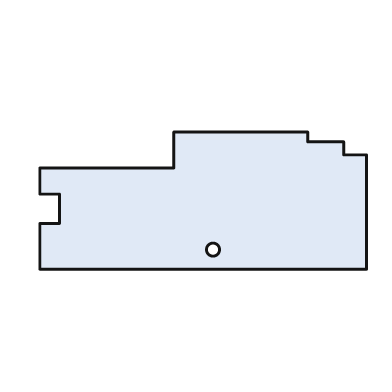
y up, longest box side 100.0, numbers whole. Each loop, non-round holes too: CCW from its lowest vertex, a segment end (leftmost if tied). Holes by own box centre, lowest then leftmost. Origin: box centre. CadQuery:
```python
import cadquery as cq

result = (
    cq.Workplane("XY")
    .moveTo(-50.0, -21.0)
    .lineTo(50.0, -21.0)
    .lineTo(50.0, 14.0)
    .lineTo(43.0, 14.0)
    .lineTo(43.0, 18.0)
    .lineTo(32.0, 18.0)
    .lineTo(32.0, 21.0)
    .lineTo(-9.0, 21.0)
    .lineTo(-9.0, 10.0)
    .lineTo(-50.0, 10.0)
    .lineTo(-50.0, 2.0)
    .lineTo(-44.0, 2.0)
    .lineTo(-44.0, -7.0)
    .lineTo(-50.0, -7.0)
    .close()
    .moveTo(3.0, -15.0)
    .circle(2.0)
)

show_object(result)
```